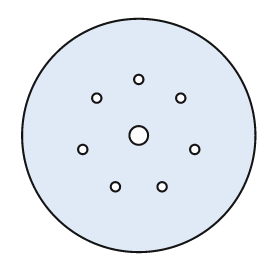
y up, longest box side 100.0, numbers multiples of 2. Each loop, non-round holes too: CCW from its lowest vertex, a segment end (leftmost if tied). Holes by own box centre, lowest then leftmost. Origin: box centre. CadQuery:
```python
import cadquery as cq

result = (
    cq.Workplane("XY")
    .moveTo(0.0, 0.0)
    .circle(50.0)
    .moveTo(-10.0, -22.0)
    .circle(2.0)
    .moveTo(10.0, -22.0)
    .circle(2.0)
    .moveTo(-24.0, -6.0)
    .circle(2.0)
    .moveTo(24.0, -6.0)
    .circle(2.0)
    .moveTo(0.0, 0.0)
    .circle(4.0)
    .moveTo(-18.0, 16.0)
    .circle(2.0)
    .moveTo(18.0, 16.0)
    .circle(2.0)
    .moveTo(0.0, 24.0)
    .circle(2.0)
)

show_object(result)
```